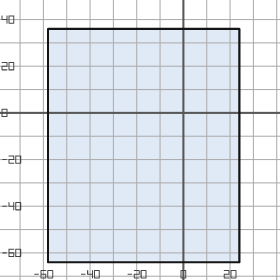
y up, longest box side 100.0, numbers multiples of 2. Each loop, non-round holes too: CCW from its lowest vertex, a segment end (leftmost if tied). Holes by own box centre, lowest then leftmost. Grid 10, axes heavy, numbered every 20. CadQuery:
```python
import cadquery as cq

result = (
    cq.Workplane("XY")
    .moveTo(-58.0, -64.0)
    .lineTo(24.0, -64.0)
    .lineTo(24.0, 36.0)
    .lineTo(-58.0, 36.0)
    .close()
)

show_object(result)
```